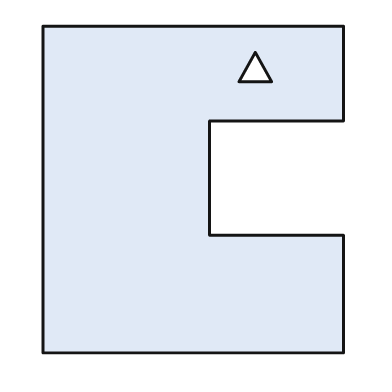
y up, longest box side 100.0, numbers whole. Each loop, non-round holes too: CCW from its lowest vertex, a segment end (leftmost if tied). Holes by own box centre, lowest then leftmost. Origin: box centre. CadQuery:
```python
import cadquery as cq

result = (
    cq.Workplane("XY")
    .moveTo(-46.0, -50.0)
    .lineTo(46.0, -50.0)
    .lineTo(46.0, -14.0)
    .lineTo(5.0, -14.0)
    .lineTo(5.0, 21.0)
    .lineTo(46.0, 21.0)
    .lineTo(46.0, 50.0)
    .lineTo(-46.0, 50.0)
    .close()
    .moveTo(14.0, 33.0)
    .lineTo(24.0, 33.0)
    .lineTo(19.0, 42.0)
    .close()
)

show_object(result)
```